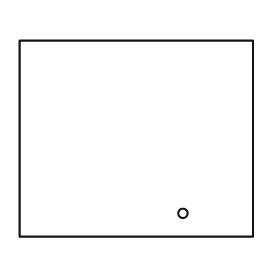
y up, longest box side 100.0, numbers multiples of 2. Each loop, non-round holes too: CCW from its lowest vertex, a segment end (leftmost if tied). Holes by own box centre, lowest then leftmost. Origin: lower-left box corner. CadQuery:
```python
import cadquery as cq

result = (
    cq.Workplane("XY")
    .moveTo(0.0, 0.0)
    .lineTo(100.0, 0.0)
    .lineTo(100.0, 84.0)
    .lineTo(0.0, 84.0)
    .close()
    .moveTo(70.0, 10.0)
    .circle(2.0)
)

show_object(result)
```